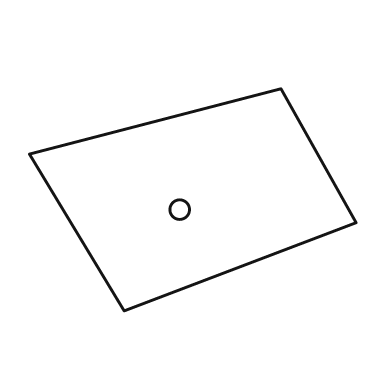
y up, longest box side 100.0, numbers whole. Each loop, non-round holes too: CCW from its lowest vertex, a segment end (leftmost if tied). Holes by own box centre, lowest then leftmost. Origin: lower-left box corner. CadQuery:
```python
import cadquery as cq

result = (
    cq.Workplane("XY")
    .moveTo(29.0, 0.0)
    .lineTo(100.0, 27.0)
    .lineTo(77.0, 68.0)
    .lineTo(0.0, 48.0)
    .close()
    .moveTo(46.0, 31.0)
    .circle(3.0)
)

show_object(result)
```